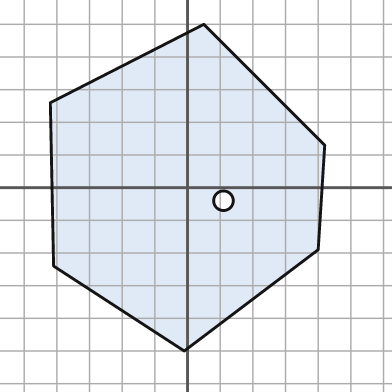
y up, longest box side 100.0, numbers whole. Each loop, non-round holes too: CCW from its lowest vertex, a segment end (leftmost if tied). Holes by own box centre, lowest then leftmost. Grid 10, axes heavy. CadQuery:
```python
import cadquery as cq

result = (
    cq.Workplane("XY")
    .moveTo(-1.0, -50.0)
    .lineTo(40.0, -19.0)
    .lineTo(42.0, 13.0)
    .lineTo(5.0, 50.0)
    .lineTo(-42.0, 26.0)
    .lineTo(-41.0, -24.0)
    .close()
    .moveTo(11.0, -4.0)
    .circle(3.0)
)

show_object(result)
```